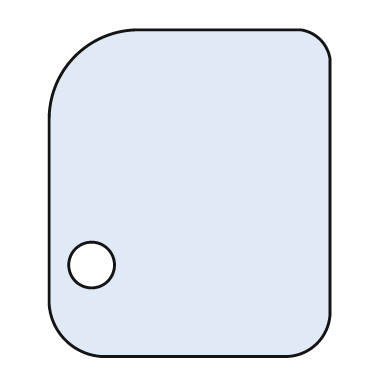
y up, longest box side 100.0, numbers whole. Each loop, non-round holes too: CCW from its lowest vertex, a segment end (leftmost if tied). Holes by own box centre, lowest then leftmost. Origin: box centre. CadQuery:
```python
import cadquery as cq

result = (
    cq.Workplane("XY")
    .moveTo(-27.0, -50.0)
    .lineTo(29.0, -50.0)
    .threePointArc((39.0, -46.0), (43.0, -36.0))
    .lineTo(43.0, 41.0)
    .threePointArc((40.0, 47.0), (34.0, 50.0))
    .lineTo(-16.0, 50.0)
    .threePointArc((-35.0, 42.0), (-43.0, 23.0))
    .lineTo(-43.0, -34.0)
    .threePointArc((-38.0, -45.0), (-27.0, -50.0))
    .close()
    .moveTo(-30.0, -22.0)
    .circle(7.0)
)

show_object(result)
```